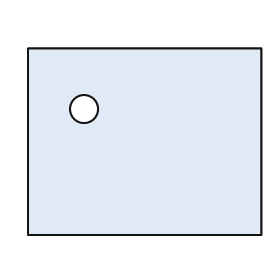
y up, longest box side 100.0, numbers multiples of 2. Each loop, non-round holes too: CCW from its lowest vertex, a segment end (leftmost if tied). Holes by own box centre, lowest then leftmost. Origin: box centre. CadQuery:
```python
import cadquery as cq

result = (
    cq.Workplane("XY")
    .moveTo(-50.0, -40.0)
    .lineTo(50.0, -40.0)
    .lineTo(50.0, 40.0)
    .lineTo(-50.0, 40.0)
    .close()
    .moveTo(-26.0, 14.0)
    .circle(6.0)
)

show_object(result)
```